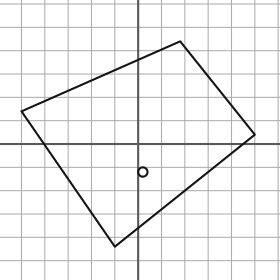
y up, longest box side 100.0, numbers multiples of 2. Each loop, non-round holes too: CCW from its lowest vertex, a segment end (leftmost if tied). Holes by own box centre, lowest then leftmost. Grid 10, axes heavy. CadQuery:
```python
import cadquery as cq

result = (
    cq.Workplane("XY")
    .moveTo(-10.0, -44.0)
    .lineTo(50.0, 4.0)
    .lineTo(18.0, 44.0)
    .lineTo(-50.0, 14.0)
    .close()
    .moveTo(2.0, -12.0)
    .circle(2.0)
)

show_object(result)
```